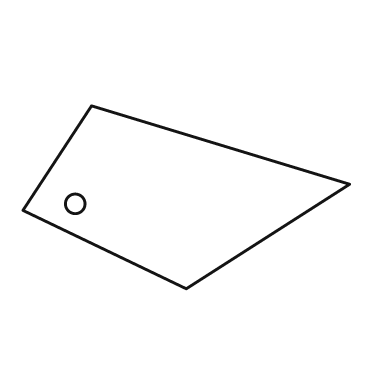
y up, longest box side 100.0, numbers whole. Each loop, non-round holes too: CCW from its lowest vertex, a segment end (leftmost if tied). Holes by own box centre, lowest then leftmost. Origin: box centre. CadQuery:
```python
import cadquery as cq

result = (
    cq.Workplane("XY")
    .moveTo(0.0, -28.0)
    .lineTo(50.0, 4.0)
    .lineTo(-29.0, 28.0)
    .lineTo(-50.0, -4.0)
    .close()
    .moveTo(-34.0, -2.0)
    .circle(3.0)
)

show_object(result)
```